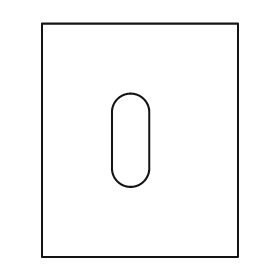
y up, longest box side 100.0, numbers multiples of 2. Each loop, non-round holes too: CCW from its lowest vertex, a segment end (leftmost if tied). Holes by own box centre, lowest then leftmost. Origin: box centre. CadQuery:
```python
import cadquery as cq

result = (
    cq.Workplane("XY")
    .moveTo(-42.0, -50.0)
    .lineTo(42.0, -50.0)
    .lineTo(42.0, 50.0)
    .lineTo(-42.0, 50.0)
    .close()
    .moveTo(-12.0, -12.0)
    .threePointArc((-4.0, -20.0), (4.0, -12.0))
    .lineTo(4.0, 12.0)
    .threePointArc((-4.0, 20.0), (-12.0, 12.0))
    .close()
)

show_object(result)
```